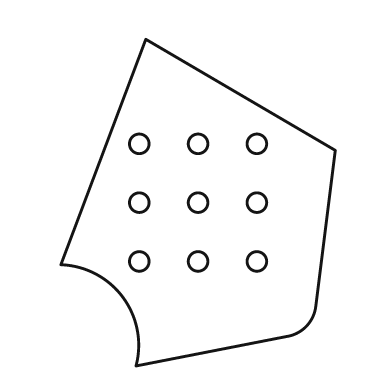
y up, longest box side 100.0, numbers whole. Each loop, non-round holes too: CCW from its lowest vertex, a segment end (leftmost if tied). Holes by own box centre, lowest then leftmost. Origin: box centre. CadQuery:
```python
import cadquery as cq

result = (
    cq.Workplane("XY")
    .moveTo(-19.0, -50.0)
    .lineTo(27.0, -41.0)
    .threePointArc((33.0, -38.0), (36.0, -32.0))
    .lineTo(42.0, 16.0)
    .lineTo(-16.0, 50.0)
    .lineTo(-42.0, -19.0)
    .threePointArc((-23.0, -29.0), (-19.0, -50.0))
    .close()
    .moveTo(-18.0, -18.0)
    .circle(3.0)
    .moveTo(0.0, -18.0)
    .circle(3.0)
    .moveTo(18.0, -18.0)
    .circle(3.0)
    .moveTo(-18.0, 0.0)
    .circle(3.0)
    .moveTo(0.0, 0.0)
    .circle(3.0)
    .moveTo(18.0, 0.0)
    .circle(3.0)
    .moveTo(-18.0, 18.0)
    .circle(3.0)
    .moveTo(0.0, 18.0)
    .circle(3.0)
    .moveTo(18.0, 18.0)
    .circle(3.0)
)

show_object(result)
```